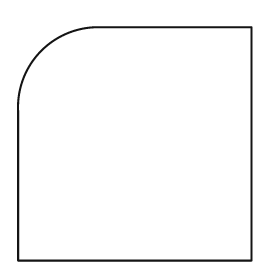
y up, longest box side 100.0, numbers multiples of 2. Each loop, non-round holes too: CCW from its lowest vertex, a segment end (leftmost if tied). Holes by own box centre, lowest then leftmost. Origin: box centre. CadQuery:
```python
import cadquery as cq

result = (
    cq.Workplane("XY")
    .moveTo(-50.0, -50.0)
    .lineTo(50.0, -50.0)
    .lineTo(50.0, 50.0)
    .lineTo(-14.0, 50.0)
    .threePointArc((-40.0, 40.0), (-50.0, 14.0))
    .close()
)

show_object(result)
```